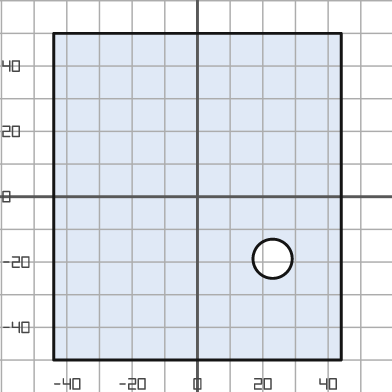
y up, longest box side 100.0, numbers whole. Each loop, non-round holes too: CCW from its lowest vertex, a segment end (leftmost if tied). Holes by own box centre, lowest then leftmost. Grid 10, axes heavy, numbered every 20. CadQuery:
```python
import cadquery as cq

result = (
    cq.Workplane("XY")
    .moveTo(-44.0, -50.0)
    .lineTo(44.0, -50.0)
    .lineTo(44.0, 50.0)
    .lineTo(-44.0, 50.0)
    .close()
    .moveTo(23.0, -19.0)
    .circle(6.0)
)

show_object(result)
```